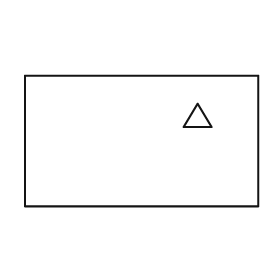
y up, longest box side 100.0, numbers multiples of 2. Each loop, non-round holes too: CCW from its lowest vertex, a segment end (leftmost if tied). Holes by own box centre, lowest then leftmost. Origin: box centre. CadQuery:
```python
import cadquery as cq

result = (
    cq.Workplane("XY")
    .moveTo(-50.0, -28.0)
    .lineTo(50.0, -28.0)
    .lineTo(50.0, 28.0)
    .lineTo(-50.0, 28.0)
    .close()
    .moveTo(18.0, 6.0)
    .lineTo(30.0, 6.0)
    .lineTo(24.0, 16.0)
    .close()
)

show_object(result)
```